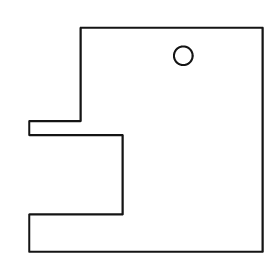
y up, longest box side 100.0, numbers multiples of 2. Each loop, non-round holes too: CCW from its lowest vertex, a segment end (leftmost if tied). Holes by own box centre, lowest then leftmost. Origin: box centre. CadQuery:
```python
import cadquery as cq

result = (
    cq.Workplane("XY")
    .moveTo(-50.0, -48.0)
    .lineTo(50.0, -48.0)
    .lineTo(50.0, 48.0)
    .lineTo(-28.0, 48.0)
    .lineTo(-28.0, 8.0)
    .lineTo(-50.0, 8.0)
    .lineTo(-50.0, 2.0)
    .lineTo(-10.0, 2.0)
    .lineTo(-10.0, -32.0)
    .lineTo(-50.0, -32.0)
    .close()
    .moveTo(16.0, 36.0)
    .circle(4.0)
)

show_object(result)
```